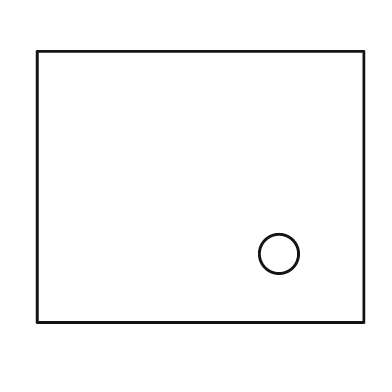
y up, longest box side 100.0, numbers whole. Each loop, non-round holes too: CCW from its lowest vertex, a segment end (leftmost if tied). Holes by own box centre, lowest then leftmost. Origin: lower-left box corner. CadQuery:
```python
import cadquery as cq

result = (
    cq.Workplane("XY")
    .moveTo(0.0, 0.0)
    .lineTo(100.0, 0.0)
    .lineTo(100.0, 83.0)
    .lineTo(0.0, 83.0)
    .close()
    .moveTo(74.0, 21.0)
    .circle(6.0)
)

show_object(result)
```